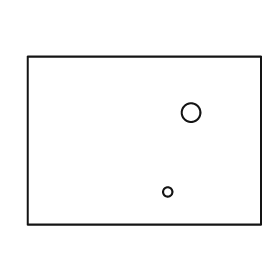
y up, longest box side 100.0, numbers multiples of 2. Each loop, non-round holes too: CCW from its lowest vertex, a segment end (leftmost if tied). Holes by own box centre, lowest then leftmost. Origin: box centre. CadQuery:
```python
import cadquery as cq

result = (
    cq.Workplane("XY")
    .moveTo(-50.0, -36.0)
    .lineTo(50.0, -36.0)
    .lineTo(50.0, 36.0)
    .lineTo(-50.0, 36.0)
    .close()
    .moveTo(10.0, -22.0)
    .circle(2.0)
    .moveTo(20.0, 12.0)
    .circle(4.0)
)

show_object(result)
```